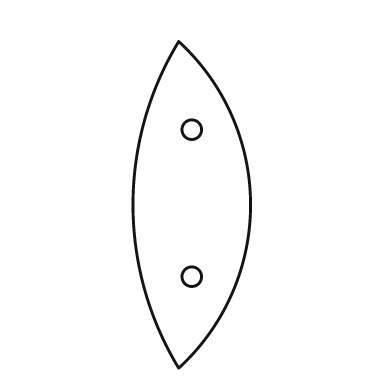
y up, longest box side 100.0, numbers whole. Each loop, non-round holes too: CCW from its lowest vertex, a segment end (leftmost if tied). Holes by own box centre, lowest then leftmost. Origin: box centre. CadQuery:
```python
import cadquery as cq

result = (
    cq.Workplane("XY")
    .moveTo(-4.0, -50.0)
    .threePointArc((18.0, 0.0), (-4.0, 50.0))
    .threePointArc((-18.0, 0.0), (-4.0, -50.0))
    .close()
    .moveTo(0.0, -22.0)
    .circle(3.0)
    .moveTo(0.0, 23.0)
    .circle(3.0)
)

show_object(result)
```